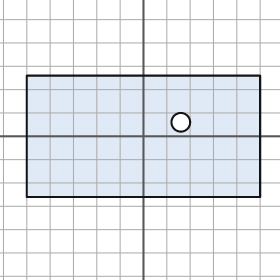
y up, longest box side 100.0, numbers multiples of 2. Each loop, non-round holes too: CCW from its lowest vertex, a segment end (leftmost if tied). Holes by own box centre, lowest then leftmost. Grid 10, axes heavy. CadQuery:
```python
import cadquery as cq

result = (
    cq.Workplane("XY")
    .moveTo(-50.0, -26.0)
    .lineTo(50.0, -26.0)
    .lineTo(50.0, 26.0)
    .lineTo(-50.0, 26.0)
    .close()
    .moveTo(16.0, 6.0)
    .circle(4.0)
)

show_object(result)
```